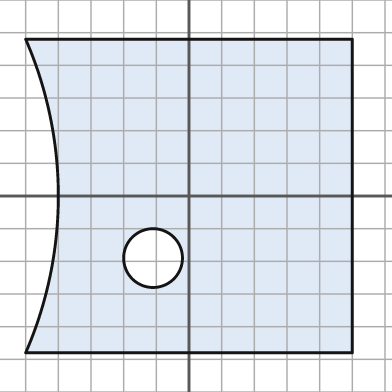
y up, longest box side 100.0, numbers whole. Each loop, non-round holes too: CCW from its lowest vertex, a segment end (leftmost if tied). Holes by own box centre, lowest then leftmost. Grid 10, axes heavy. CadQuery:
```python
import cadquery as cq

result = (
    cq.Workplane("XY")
    .moveTo(-50.0, -48.0)
    .lineTo(50.0, -48.0)
    .lineTo(50.0, 48.0)
    .lineTo(-50.0, 48.0)
    .threePointArc((-40.0, 0.0), (-50.0, -48.0))
    .close()
    .moveTo(-11.0, -19.0)
    .circle(9.0)
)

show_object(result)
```